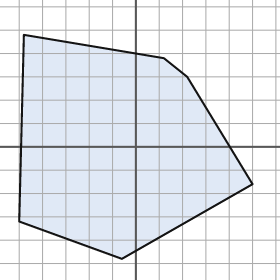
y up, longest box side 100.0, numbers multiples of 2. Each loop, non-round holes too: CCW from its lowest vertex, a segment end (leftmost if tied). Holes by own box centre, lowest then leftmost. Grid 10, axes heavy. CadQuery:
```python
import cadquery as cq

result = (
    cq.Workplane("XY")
    .moveTo(-6.0, -48.0)
    .lineTo(50.0, -16.0)
    .lineTo(22.0, 30.0)
    .lineTo(12.0, 38.0)
    .lineTo(-48.0, 48.0)
    .lineTo(-50.0, -32.0)
    .close()
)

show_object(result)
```